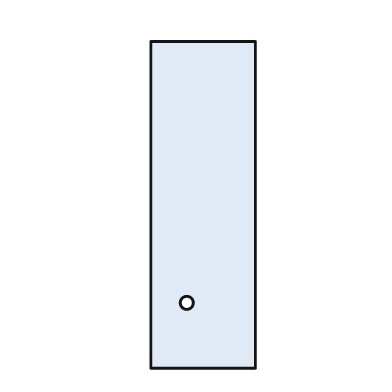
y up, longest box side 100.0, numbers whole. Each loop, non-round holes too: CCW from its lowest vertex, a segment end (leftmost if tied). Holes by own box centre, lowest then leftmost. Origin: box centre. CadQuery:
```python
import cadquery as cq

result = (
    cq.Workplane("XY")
    .moveTo(-16.0, -50.0)
    .lineTo(16.0, -50.0)
    .lineTo(16.0, 50.0)
    .lineTo(-16.0, 50.0)
    .close()
    .moveTo(-5.0, -30.0)
    .circle(2.0)
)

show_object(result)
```